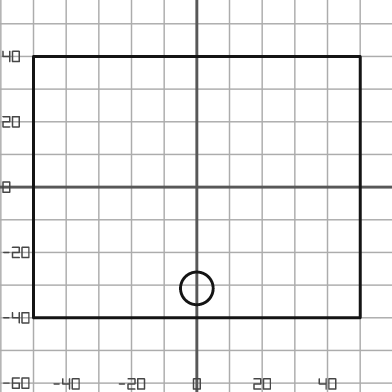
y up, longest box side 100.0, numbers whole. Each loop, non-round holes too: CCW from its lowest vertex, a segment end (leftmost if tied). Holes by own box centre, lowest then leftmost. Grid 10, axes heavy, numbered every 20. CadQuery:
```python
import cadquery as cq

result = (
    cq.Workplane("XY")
    .moveTo(-50.0, -40.0)
    .lineTo(50.0, -40.0)
    .lineTo(50.0, 40.0)
    .lineTo(-50.0, 40.0)
    .close()
    .moveTo(0.0, -31.0)
    .circle(5.0)
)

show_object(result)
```